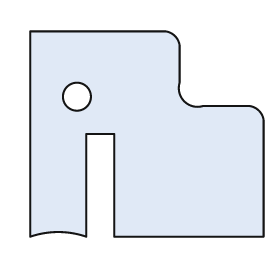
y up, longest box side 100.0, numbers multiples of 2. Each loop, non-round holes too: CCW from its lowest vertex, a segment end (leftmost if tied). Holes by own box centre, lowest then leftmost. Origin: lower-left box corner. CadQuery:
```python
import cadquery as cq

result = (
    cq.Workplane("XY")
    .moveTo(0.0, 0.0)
    .threePointArc((12.0, 2.0), (24.0, 0.0))
    .lineTo(24.0, 44.0)
    .lineTo(36.0, 44.0)
    .lineTo(36.0, 0.0)
    .lineTo(100.0, 0.0)
    .lineTo(100.0, 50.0)
    .threePointArc((98.0, 54.0), (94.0, 56.0))
    .lineTo(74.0, 56.0)
    .threePointArc((66.0, 58.0), (64.0, 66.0))
    .lineTo(64.0, 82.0)
    .threePointArc((62.0, 86.0), (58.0, 88.0))
    .lineTo(0.0, 88.0)
    .close()
    .moveTo(20.0, 60.0)
    .circle(6.0)
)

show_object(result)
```